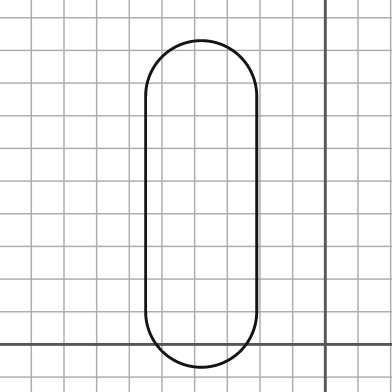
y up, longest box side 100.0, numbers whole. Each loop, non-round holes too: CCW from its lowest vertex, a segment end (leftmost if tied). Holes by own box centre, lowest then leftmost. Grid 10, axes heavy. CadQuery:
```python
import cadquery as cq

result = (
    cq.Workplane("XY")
    .moveTo(-55.0, 10.0)
    .threePointArc((-38.0, -7.0), (-21.0, 10.0))
    .lineTo(-21.0, 76.0)
    .threePointArc((-38.0, 93.0), (-55.0, 76.0))
    .close()
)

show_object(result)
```